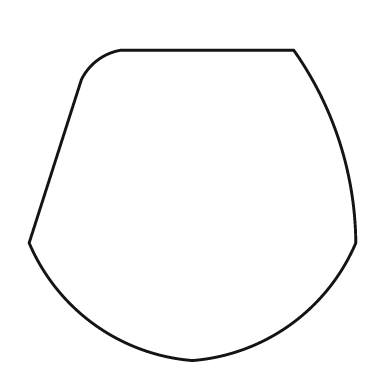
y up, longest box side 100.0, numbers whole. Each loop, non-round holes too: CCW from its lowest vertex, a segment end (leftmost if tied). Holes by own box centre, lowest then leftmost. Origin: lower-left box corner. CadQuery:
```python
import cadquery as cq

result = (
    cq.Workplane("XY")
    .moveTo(50.0, 0.0)
    .threePointArc((80.0, 11.0), (100.0, 36.0))
    .threePointArc((95.0, 67.0), (81.0, 95.0))
    .lineTo(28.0, 95.0)
    .threePointArc((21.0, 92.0), (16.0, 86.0))
    .lineTo(0.0, 36.0)
    .threePointArc((20.0, 11.0), (50.0, 0.0))
    .close()
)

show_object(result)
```